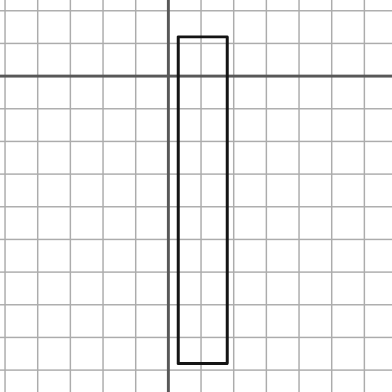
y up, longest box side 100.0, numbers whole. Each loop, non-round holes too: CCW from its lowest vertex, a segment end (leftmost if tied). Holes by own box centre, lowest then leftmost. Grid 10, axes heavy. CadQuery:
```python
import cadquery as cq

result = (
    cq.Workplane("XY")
    .moveTo(3.0, -88.0)
    .lineTo(18.0, -88.0)
    .lineTo(18.0, 12.0)
    .lineTo(3.0, 12.0)
    .close()
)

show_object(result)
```